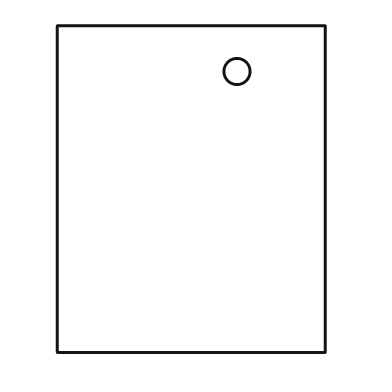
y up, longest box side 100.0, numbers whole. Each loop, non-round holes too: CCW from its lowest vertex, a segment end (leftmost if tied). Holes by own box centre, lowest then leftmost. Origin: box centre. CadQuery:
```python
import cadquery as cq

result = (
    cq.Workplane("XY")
    .moveTo(-41.0, -50.0)
    .lineTo(41.0, -50.0)
    .lineTo(41.0, 50.0)
    .lineTo(-41.0, 50.0)
    .close()
    .moveTo(14.0, 36.0)
    .circle(4.0)
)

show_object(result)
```